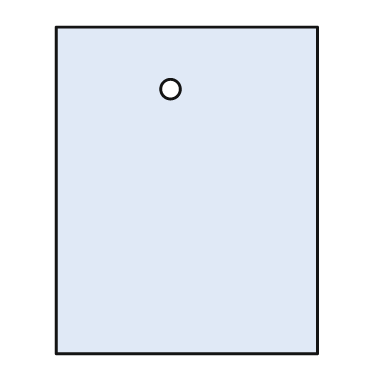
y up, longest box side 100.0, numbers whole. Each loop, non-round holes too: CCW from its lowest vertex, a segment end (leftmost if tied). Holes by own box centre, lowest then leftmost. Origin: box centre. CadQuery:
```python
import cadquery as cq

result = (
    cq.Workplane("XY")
    .moveTo(-40.0, -50.0)
    .lineTo(40.0, -50.0)
    .lineTo(40.0, 50.0)
    .lineTo(-40.0, 50.0)
    .close()
    .moveTo(-5.0, 31.0)
    .circle(3.0)
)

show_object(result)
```